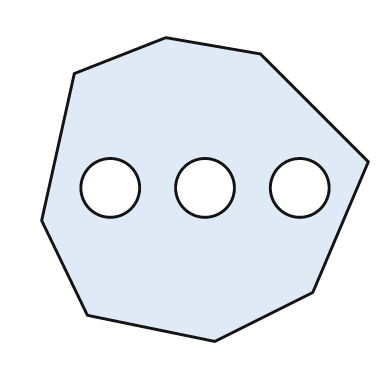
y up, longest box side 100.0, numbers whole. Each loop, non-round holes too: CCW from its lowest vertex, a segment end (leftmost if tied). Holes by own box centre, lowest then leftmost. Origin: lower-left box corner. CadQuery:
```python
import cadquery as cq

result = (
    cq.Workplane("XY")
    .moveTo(53.0, 0.0)
    .lineTo(83.0, 15.0)
    .lineTo(100.0, 55.0)
    .lineTo(67.0, 88.0)
    .lineTo(38.0, 93.0)
    .lineTo(10.0, 82.0)
    .lineTo(0.0, 37.0)
    .lineTo(14.0, 8.0)
    .close()
    .moveTo(21.0, 47.0)
    .circle(9.0)
    .moveTo(50.0, 47.0)
    .circle(9.0)
    .moveTo(79.0, 47.0)
    .circle(9.0)
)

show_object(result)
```